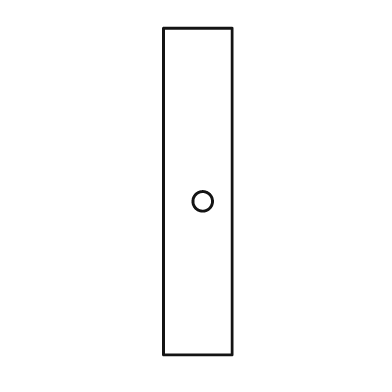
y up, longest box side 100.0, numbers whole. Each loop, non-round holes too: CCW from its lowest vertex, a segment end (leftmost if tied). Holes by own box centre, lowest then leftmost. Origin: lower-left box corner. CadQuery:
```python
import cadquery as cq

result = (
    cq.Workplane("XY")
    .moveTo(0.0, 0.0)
    .lineTo(21.0, 0.0)
    .lineTo(21.0, 100.0)
    .lineTo(0.0, 100.0)
    .close()
    .moveTo(12.0, 47.0)
    .circle(3.0)
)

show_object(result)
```